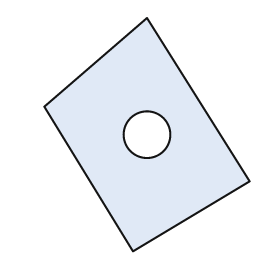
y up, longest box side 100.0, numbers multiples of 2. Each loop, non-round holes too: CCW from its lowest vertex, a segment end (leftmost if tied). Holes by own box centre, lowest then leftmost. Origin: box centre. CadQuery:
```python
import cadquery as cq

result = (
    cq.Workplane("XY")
    .moveTo(-6.0, -50.0)
    .lineTo(44.0, -20.0)
    .lineTo(0.0, 50.0)
    .lineTo(-44.0, 12.0)
    .close()
    .moveTo(0.0, 0.0)
    .circle(10.0)
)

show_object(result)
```